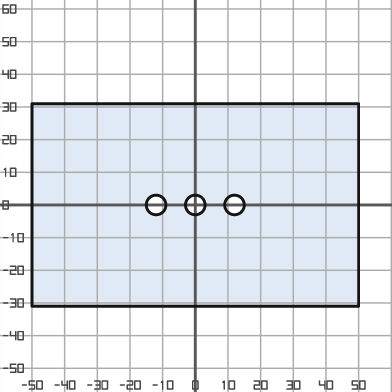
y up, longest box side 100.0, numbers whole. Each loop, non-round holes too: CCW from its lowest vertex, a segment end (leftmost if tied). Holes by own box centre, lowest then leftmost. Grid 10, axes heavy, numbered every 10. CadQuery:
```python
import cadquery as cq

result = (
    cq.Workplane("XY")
    .moveTo(-50.0, -31.0)
    .lineTo(50.0, -31.0)
    .lineTo(50.0, 31.0)
    .lineTo(-50.0, 31.0)
    .close()
    .moveTo(-12.0, 0.0)
    .circle(3.0)
    .moveTo(0.0, 0.0)
    .circle(3.0)
    .moveTo(12.0, 0.0)
    .circle(3.0)
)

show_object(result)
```